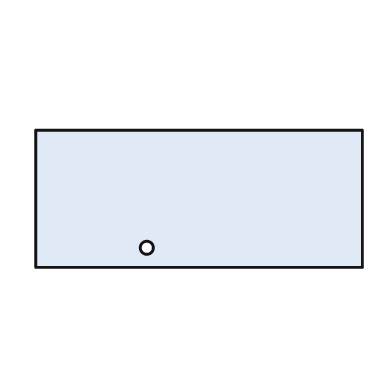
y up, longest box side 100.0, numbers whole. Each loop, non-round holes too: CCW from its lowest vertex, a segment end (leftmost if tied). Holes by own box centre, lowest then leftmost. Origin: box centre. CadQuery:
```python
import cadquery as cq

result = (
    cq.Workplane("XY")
    .moveTo(-50.0, -21.0)
    .lineTo(50.0, -21.0)
    .lineTo(50.0, 21.0)
    .lineTo(-50.0, 21.0)
    .close()
    .moveTo(-16.0, -15.0)
    .circle(2.0)
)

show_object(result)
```